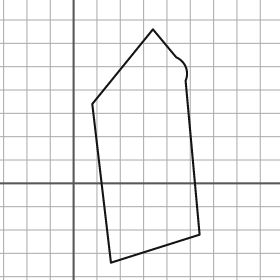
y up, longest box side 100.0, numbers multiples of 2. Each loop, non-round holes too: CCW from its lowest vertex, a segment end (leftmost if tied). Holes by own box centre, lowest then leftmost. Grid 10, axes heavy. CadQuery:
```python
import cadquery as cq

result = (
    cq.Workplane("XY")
    .moveTo(16.0, -34.0)
    .lineTo(54.0, -22.0)
    .lineTo(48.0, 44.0)
    .threePointArc((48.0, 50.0), (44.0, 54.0))
    .lineTo(34.0, 66.0)
    .lineTo(8.0, 34.0)
    .close()
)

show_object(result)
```